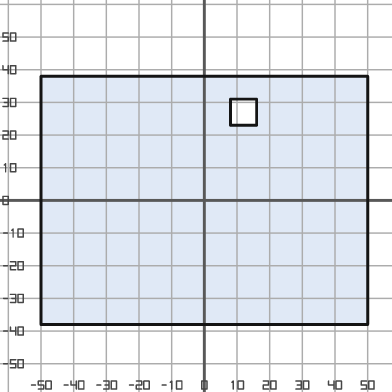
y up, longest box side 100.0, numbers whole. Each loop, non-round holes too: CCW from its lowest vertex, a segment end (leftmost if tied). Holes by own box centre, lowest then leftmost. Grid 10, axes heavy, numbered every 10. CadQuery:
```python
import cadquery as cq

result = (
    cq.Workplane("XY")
    .moveTo(-50.0, -38.0)
    .lineTo(50.0, -38.0)
    .lineTo(50.0, 38.0)
    .lineTo(-50.0, 38.0)
    .close()
    .moveTo(8.0, 23.0)
    .lineTo(16.0, 23.0)
    .lineTo(16.0, 31.0)
    .lineTo(8.0, 31.0)
    .close()
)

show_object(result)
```